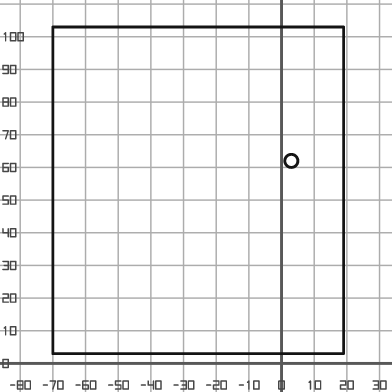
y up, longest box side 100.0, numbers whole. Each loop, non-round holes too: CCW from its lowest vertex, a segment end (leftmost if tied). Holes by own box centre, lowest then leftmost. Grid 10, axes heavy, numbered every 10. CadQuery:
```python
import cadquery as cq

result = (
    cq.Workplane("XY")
    .moveTo(-70.0, 3.0)
    .lineTo(19.0, 3.0)
    .lineTo(19.0, 103.0)
    .lineTo(-70.0, 103.0)
    .close()
    .moveTo(3.0, 62.0)
    .circle(2.0)
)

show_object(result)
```